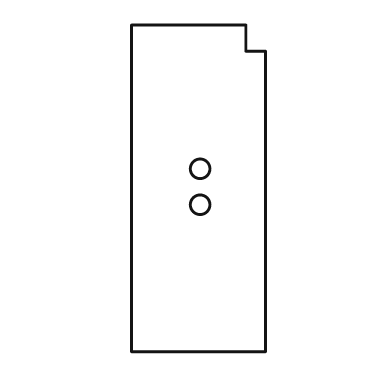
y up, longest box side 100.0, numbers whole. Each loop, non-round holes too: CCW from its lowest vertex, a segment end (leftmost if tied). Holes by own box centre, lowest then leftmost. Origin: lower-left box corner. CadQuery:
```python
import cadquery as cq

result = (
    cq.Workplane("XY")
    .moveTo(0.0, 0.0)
    .lineTo(41.0, 0.0)
    .lineTo(41.0, 92.0)
    .lineTo(35.0, 92.0)
    .lineTo(35.0, 100.0)
    .lineTo(0.0, 100.0)
    .close()
    .moveTo(21.0, 45.0)
    .circle(3.0)
    .moveTo(21.0, 56.0)
    .circle(3.0)
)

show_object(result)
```